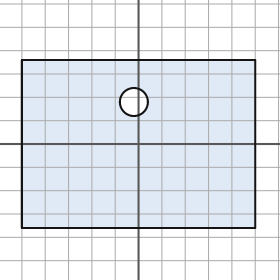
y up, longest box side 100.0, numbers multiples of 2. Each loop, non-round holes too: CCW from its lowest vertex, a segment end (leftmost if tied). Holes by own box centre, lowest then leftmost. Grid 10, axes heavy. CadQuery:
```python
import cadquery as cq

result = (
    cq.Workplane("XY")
    .moveTo(-50.0, -36.0)
    .lineTo(50.0, -36.0)
    .lineTo(50.0, 36.0)
    .lineTo(-50.0, 36.0)
    .close()
    .moveTo(-2.0, 18.0)
    .circle(6.0)
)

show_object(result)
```